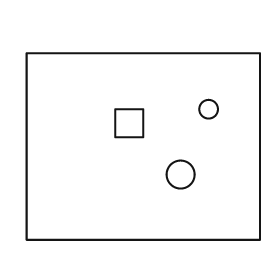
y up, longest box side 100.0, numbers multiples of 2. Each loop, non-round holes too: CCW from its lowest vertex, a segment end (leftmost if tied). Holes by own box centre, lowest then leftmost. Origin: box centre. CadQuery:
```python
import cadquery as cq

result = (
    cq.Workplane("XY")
    .moveTo(-50.0, -40.0)
    .lineTo(50.0, -40.0)
    .lineTo(50.0, 40.0)
    .lineTo(-50.0, 40.0)
    .close()
    .moveTo(16.0, -12.0)
    .circle(6.0)
    .moveTo(-12.0, 4.0)
    .lineTo(0.0, 4.0)
    .lineTo(0.0, 16.0)
    .lineTo(-12.0, 16.0)
    .close()
    .moveTo(28.0, 16.0)
    .circle(4.0)
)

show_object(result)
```